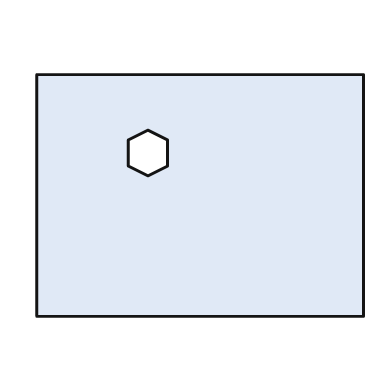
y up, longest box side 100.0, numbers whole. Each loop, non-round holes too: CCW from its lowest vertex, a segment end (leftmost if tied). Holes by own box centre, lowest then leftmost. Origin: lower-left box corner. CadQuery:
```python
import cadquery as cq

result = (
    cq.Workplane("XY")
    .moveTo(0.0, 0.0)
    .lineTo(100.0, 0.0)
    .lineTo(100.0, 74.0)
    .lineTo(0.0, 74.0)
    .close()
    .moveTo(34.0, 43.0)
    .lineTo(40.0, 46.0)
    .lineTo(40.0, 54.0)
    .lineTo(34.0, 57.0)
    .lineTo(28.0, 54.0)
    .lineTo(28.0, 46.0)
    .close()
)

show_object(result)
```